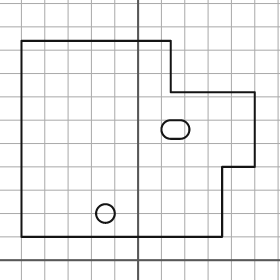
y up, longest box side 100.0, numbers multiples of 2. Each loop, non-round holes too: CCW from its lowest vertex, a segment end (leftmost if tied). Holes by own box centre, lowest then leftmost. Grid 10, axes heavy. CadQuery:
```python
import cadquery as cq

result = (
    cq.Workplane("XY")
    .moveTo(-50.0, 10.0)
    .lineTo(36.0, 10.0)
    .lineTo(36.0, 40.0)
    .lineTo(50.0, 40.0)
    .lineTo(50.0, 72.0)
    .lineTo(14.0, 72.0)
    .lineTo(14.0, 94.0)
    .lineTo(-50.0, 94.0)
    .close()
    .moveTo(-14.0, 20.0)
    .circle(4.0)
    .moveTo(14.0, 52.0)
    .lineTo(18.0, 52.0)
    .threePointArc((22.0, 56.0), (18.0, 60.0))
    .lineTo(14.0, 60.0)
    .threePointArc((10.0, 56.0), (14.0, 52.0))
    .close()
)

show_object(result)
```